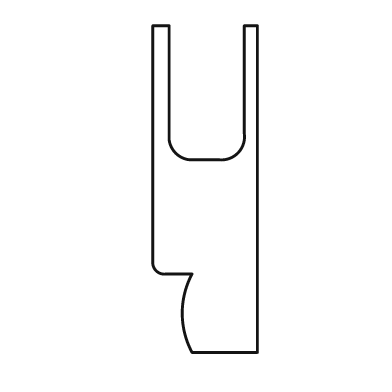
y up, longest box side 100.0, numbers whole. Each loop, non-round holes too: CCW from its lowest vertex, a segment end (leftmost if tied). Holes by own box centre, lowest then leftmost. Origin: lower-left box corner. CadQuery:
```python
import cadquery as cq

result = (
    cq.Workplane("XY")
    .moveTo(12.0, 0.0)
    .lineTo(32.0, 0.0)
    .lineTo(32.0, 100.0)
    .lineTo(28.0, 100.0)
    .lineTo(28.0, 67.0)
    .threePointArc((26.0, 61.0), (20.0, 59.0))
    .lineTo(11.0, 59.0)
    .threePointArc((7.0, 61.0), (5.0, 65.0))
    .lineTo(5.0, 100.0)
    .lineTo(0.0, 100.0)
    .lineTo(0.0, 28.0)
    .threePointArc((1.0, 25.0), (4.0, 24.0))
    .lineTo(12.0, 24.0)
    .threePointArc((9.0, 12.0), (12.0, 0.0))
    .close()
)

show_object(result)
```